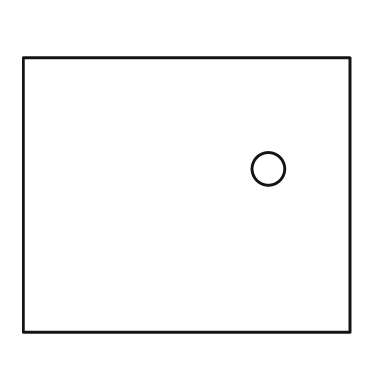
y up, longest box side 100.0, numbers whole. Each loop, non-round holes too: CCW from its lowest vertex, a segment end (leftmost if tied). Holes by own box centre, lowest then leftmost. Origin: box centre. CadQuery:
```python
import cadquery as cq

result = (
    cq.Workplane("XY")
    .moveTo(-50.0, -42.0)
    .lineTo(50.0, -42.0)
    .lineTo(50.0, 42.0)
    .lineTo(-50.0, 42.0)
    .close()
    .moveTo(25.0, 8.0)
    .circle(5.0)
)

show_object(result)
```